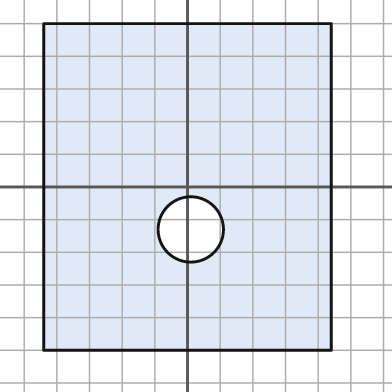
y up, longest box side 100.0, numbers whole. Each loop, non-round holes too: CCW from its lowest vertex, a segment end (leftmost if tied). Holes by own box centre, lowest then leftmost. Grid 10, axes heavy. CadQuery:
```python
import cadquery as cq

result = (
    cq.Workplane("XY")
    .moveTo(-44.0, -50.0)
    .lineTo(44.0, -50.0)
    .lineTo(44.0, 50.0)
    .lineTo(-44.0, 50.0)
    .close()
    .moveTo(1.0, -13.0)
    .circle(10.0)
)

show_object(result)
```